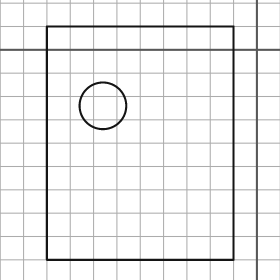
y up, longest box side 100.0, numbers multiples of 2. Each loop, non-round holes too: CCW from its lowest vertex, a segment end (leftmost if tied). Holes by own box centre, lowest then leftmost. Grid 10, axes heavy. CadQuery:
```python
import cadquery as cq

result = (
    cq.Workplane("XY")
    .moveTo(-90.0, -90.0)
    .lineTo(-10.0, -90.0)
    .lineTo(-10.0, 10.0)
    .lineTo(-90.0, 10.0)
    .close()
    .moveTo(-66.0, -24.0)
    .circle(10.0)
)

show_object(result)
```